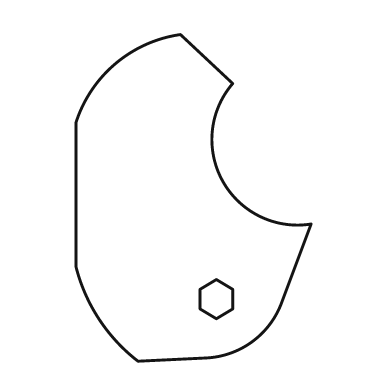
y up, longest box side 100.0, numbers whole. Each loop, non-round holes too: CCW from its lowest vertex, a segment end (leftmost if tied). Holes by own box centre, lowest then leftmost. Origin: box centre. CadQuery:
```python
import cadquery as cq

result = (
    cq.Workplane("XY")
    .moveTo(-17.0, -50.0)
    .lineTo(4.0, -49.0)
    .threePointArc((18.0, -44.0), (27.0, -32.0))
    .lineTo(36.0, -8.0)
    .threePointArc((9.0, 5.0), (12.0, 35.0))
    .lineTo(-4.0, 50.0)
    .threePointArc((-24.0, 41.0), (-36.0, 23.0))
    .lineTo(-36.0, -21.0)
    .threePointArc((-29.0, -37.0), (-17.0, -50.0))
    .close()
    .moveTo(7.0, -37.0)
    .lineTo(12.0, -34.0)
    .lineTo(12.0, -28.0)
    .lineTo(7.0, -25.0)
    .lineTo(2.0, -28.0)
    .lineTo(2.0, -34.0)
    .close()
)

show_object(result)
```